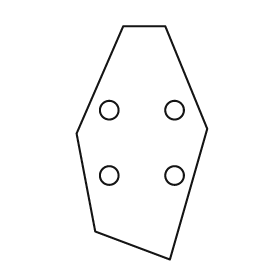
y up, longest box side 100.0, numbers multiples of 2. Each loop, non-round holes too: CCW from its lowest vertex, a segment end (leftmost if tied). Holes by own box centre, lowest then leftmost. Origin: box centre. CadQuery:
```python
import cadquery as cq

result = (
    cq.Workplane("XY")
    .moveTo(12.0, -50.0)
    .lineTo(28.0, 6.0)
    .lineTo(10.0, 50.0)
    .lineTo(-8.0, 50.0)
    .lineTo(-28.0, 4.0)
    .lineTo(-20.0, -38.0)
    .close()
    .moveTo(-14.0, -14.0)
    .circle(4.0)
    .moveTo(14.0, -14.0)
    .circle(4.0)
    .moveTo(-14.0, 14.0)
    .circle(4.0)
    .moveTo(14.0, 14.0)
    .circle(4.0)
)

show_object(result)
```